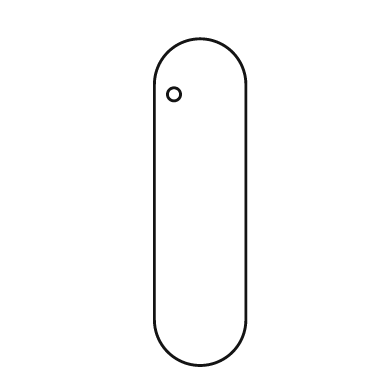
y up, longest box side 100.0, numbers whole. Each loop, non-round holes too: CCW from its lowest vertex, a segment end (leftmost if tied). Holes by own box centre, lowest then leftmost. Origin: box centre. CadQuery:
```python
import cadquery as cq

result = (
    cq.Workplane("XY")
    .moveTo(-14.0, -36.0)
    .threePointArc((0.0, -50.0), (14.0, -36.0))
    .lineTo(14.0, 36.0)
    .threePointArc((0.0, 50.0), (-14.0, 36.0))
    .close()
    .moveTo(-8.0, 33.0)
    .circle(2.0)
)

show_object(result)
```